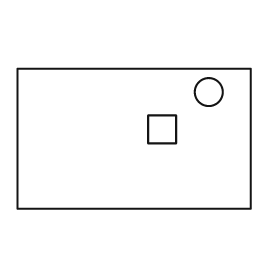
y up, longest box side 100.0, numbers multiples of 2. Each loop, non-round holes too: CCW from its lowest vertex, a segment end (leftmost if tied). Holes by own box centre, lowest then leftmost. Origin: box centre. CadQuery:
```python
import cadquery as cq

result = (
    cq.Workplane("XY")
    .moveTo(-50.0, -30.0)
    .lineTo(50.0, -30.0)
    .lineTo(50.0, 30.0)
    .lineTo(-50.0, 30.0)
    .close()
    .moveTo(6.0, -2.0)
    .lineTo(18.0, -2.0)
    .lineTo(18.0, 10.0)
    .lineTo(6.0, 10.0)
    .close()
    .moveTo(32.0, 20.0)
    .circle(6.0)
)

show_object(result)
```